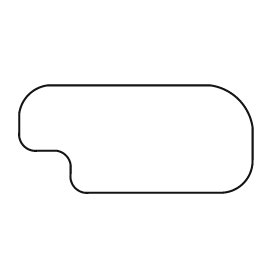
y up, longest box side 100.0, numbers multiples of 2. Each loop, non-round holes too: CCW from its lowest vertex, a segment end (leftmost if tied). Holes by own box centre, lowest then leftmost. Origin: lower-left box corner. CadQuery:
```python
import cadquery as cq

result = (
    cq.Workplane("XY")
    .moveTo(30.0, 0.0)
    .lineTo(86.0, 0.0)
    .threePointArc((96.0, 4.0), (100.0, 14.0))
    .lineTo(100.0, 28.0)
    .threePointArc((94.0, 40.0), (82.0, 46.0))
    .lineTo(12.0, 46.0)
    .threePointArc((4.0, 42.0), (0.0, 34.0))
    .lineTo(0.0, 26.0)
    .threePointArc((2.0, 20.0), (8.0, 18.0))
    .lineTo(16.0, 18.0)
    .threePointArc((20.0, 16.0), (22.0, 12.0))
    .lineTo(22.0, 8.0)
    .threePointArc((24.0, 2.0), (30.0, 0.0))
    .close()
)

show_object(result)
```